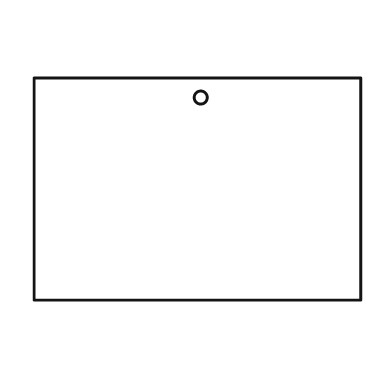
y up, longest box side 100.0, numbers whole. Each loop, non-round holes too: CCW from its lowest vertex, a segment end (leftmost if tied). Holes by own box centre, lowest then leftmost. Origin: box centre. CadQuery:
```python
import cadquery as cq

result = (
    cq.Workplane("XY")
    .moveTo(-50.0, -34.0)
    .lineTo(50.0, -34.0)
    .lineTo(50.0, 34.0)
    .lineTo(-50.0, 34.0)
    .close()
    .moveTo(1.0, 28.0)
    .circle(2.0)
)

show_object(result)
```